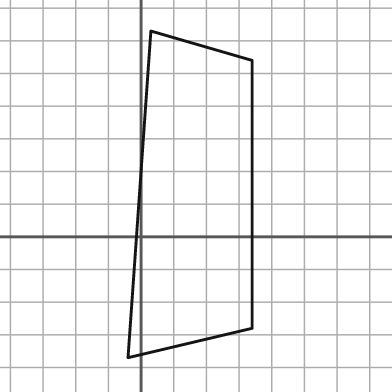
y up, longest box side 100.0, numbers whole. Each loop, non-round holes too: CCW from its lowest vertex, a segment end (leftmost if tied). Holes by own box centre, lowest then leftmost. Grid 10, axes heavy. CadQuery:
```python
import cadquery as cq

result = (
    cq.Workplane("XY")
    .moveTo(-4.0, -37.0)
    .lineTo(34.0, -28.0)
    .lineTo(34.0, 54.0)
    .lineTo(3.0, 63.0)
    .close()
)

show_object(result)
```